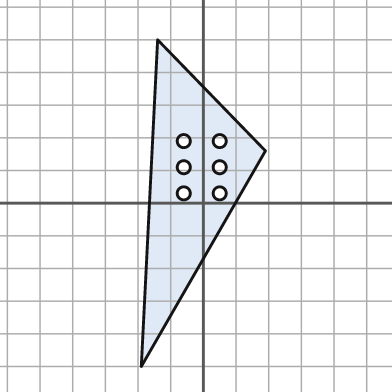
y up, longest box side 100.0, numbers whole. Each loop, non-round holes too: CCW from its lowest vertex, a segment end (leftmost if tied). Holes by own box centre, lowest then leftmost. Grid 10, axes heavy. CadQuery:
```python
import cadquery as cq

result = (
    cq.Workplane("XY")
    .moveTo(-19.0, -50.0)
    .lineTo(19.0, 16.0)
    .lineTo(-14.0, 50.0)
    .close()
    .moveTo(-6.0, 3.0)
    .circle(2.0)
    .moveTo(5.0, 3.0)
    .circle(2.0)
    .moveTo(-6.0, 11.0)
    .circle(2.0)
    .moveTo(5.0, 11.0)
    .circle(2.0)
    .moveTo(-6.0, 19.0)
    .circle(2.0)
    .moveTo(5.0, 19.0)
    .circle(2.0)
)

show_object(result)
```